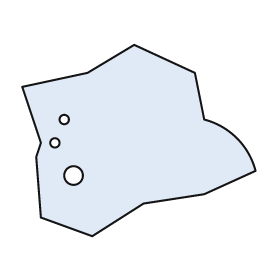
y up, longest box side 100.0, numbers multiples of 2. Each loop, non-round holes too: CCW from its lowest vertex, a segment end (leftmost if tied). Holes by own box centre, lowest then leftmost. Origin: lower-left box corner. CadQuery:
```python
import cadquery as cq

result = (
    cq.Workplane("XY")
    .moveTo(30.0, 0.0)
    .lineTo(52.0, 14.0)
    .lineTo(78.0, 18.0)
    .lineTo(100.0, 28.0)
    .threePointArc((92.0, 42.0), (78.0, 50.0))
    .lineTo(74.0, 70.0)
    .lineTo(48.0, 82.0)
    .lineTo(28.0, 70.0)
    .lineTo(0.0, 64.0)
    .lineTo(8.0, 40.0)
    .lineTo(6.0, 34.0)
    .lineTo(8.0, 8.0)
    .close()
    .moveTo(22.0, 26.0)
    .circle(4.0)
    .moveTo(14.0, 40.0)
    .circle(2.0)
    .moveTo(18.0, 50.0)
    .circle(2.0)
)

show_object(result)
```